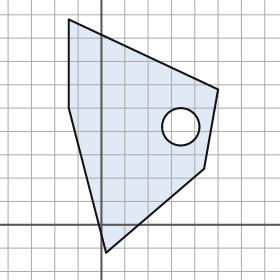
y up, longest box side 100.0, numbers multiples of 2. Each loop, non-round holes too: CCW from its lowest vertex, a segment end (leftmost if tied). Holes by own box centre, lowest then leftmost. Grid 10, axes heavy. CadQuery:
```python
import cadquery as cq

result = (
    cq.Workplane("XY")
    .moveTo(2.0, -12.0)
    .lineTo(44.0, 24.0)
    .lineTo(50.0, 58.0)
    .lineTo(-14.0, 88.0)
    .lineTo(-14.0, 50.0)
    .close()
    .moveTo(34.0, 42.0)
    .circle(8.0)
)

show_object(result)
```